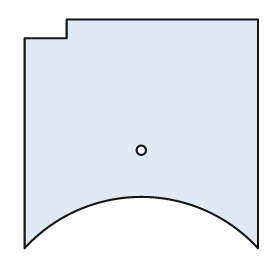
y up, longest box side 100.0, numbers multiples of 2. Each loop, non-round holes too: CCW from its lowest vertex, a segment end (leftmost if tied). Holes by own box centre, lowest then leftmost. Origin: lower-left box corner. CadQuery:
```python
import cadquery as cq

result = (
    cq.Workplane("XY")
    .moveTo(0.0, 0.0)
    .threePointArc((50.0, 22.0), (100.0, 0.0))
    .lineTo(100.0, 98.0)
    .lineTo(18.0, 98.0)
    .lineTo(18.0, 90.0)
    .lineTo(0.0, 90.0)
    .close()
    .moveTo(50.0, 42.0)
    .circle(2.0)
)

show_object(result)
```